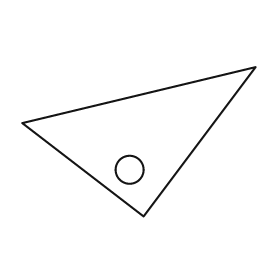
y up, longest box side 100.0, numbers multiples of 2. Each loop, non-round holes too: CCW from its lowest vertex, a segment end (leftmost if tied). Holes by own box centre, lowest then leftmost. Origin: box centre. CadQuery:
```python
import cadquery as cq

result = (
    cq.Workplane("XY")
    .moveTo(2.0, -32.0)
    .lineTo(50.0, 32.0)
    .lineTo(-50.0, 8.0)
    .close()
    .moveTo(-4.0, -12.0)
    .circle(6.0)
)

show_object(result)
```